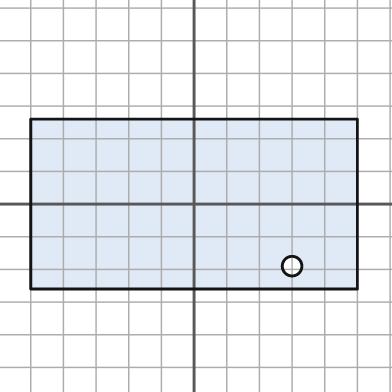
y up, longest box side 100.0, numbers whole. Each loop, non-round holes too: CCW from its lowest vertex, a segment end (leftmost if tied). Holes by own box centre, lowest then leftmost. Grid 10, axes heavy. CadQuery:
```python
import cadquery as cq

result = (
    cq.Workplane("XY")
    .moveTo(-50.0, -26.0)
    .lineTo(50.0, -26.0)
    .lineTo(50.0, 26.0)
    .lineTo(-50.0, 26.0)
    .close()
    .moveTo(30.0, -19.0)
    .circle(3.0)
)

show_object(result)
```